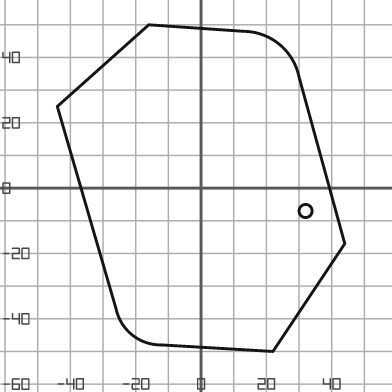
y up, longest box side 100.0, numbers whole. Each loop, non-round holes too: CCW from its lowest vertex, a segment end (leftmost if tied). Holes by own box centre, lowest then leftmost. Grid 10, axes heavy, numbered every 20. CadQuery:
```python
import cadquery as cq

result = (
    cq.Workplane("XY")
    .moveTo(22.0, -50.0)
    .lineTo(44.0, -17.0)
    .lineTo(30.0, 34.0)
    .threePointArc((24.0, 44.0), (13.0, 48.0))
    .lineTo(-16.0, 50.0)
    .lineTo(-44.0, 25.0)
    .lineTo(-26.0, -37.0)
    .threePointArc((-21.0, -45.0), (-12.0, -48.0))
    .close()
    .moveTo(32.0, -7.0)
    .circle(2.0)
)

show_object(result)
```